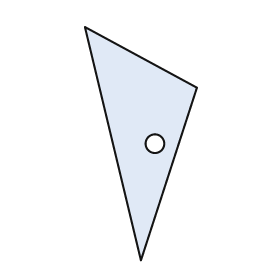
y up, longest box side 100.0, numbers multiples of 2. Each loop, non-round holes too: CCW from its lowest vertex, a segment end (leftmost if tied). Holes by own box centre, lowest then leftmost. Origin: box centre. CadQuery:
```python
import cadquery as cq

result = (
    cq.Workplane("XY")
    .moveTo(0.0, -50.0)
    .lineTo(24.0, 24.0)
    .lineTo(-24.0, 50.0)
    .close()
    .moveTo(6.0, 0.0)
    .circle(4.0)
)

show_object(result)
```